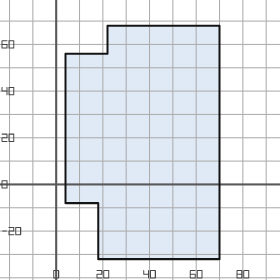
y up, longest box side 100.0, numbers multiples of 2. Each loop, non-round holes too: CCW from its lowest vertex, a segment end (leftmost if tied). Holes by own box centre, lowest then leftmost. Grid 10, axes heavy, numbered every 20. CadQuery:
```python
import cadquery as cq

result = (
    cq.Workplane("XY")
    .moveTo(18.0, -32.0)
    .lineTo(70.0, -32.0)
    .lineTo(70.0, 68.0)
    .lineTo(22.0, 68.0)
    .lineTo(22.0, 56.0)
    .lineTo(4.0, 56.0)
    .lineTo(4.0, -8.0)
    .lineTo(18.0, -8.0)
    .close()
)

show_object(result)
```